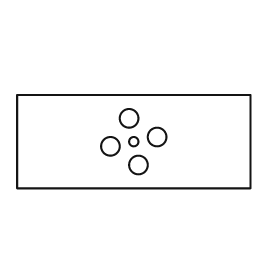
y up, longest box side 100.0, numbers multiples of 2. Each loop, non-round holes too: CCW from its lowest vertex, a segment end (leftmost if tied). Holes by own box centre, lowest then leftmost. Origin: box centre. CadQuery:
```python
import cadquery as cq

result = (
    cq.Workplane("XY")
    .moveTo(-50.0, -20.0)
    .lineTo(50.0, -20.0)
    .lineTo(50.0, 20.0)
    .lineTo(-50.0, 20.0)
    .close()
    .moveTo(2.0, -10.0)
    .circle(4.0)
    .moveTo(-10.0, -2.0)
    .circle(4.0)
    .moveTo(0.0, 0.0)
    .circle(2.0)
    .moveTo(10.0, 2.0)
    .circle(4.0)
    .moveTo(-2.0, 10.0)
    .circle(4.0)
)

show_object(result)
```